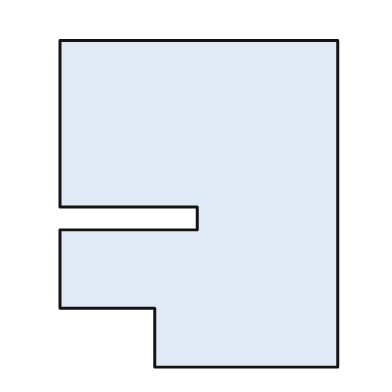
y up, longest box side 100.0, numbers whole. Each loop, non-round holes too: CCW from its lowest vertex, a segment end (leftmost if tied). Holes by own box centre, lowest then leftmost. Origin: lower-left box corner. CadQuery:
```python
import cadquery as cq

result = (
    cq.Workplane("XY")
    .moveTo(29.0, 0.0)
    .lineTo(85.0, 0.0)
    .lineTo(85.0, 100.0)
    .lineTo(0.0, 100.0)
    .lineTo(0.0, 49.0)
    .lineTo(42.0, 49.0)
    .lineTo(42.0, 42.0)
    .lineTo(0.0, 42.0)
    .lineTo(0.0, 18.0)
    .lineTo(29.0, 18.0)
    .close()
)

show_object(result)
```